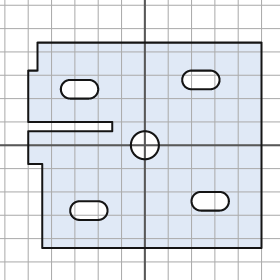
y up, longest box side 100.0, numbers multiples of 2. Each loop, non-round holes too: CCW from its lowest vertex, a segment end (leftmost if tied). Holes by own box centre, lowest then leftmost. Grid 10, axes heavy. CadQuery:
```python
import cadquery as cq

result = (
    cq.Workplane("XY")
    .moveTo(-44.0, -44.0)
    .lineTo(50.0, -44.0)
    .lineTo(50.0, 44.0)
    .lineTo(-46.0, 44.0)
    .lineTo(-46.0, 32.0)
    .lineTo(-50.0, 32.0)
    .lineTo(-50.0, 10.0)
    .lineTo(-14.0, 10.0)
    .lineTo(-14.0, 6.0)
    .lineTo(-50.0, 6.0)
    .lineTo(-50.0, -8.0)
    .lineTo(-44.0, -8.0)
    .close()
    .moveTo(-28.0, -32.0)
    .lineTo(-20.0, -32.0)
    .threePointArc((-16.0, -28.0), (-20.0, -24.0))
    .lineTo(-28.0, -24.0)
    .threePointArc((-32.0, -28.0), (-28.0, -32.0))
    .close()
    .moveTo(24.0, -28.0)
    .lineTo(32.0, -28.0)
    .threePointArc((36.0, -24.0), (32.0, -20.0))
    .lineTo(24.0, -20.0)
    .threePointArc((20.0, -24.0), (24.0, -28.0))
    .close()
    .moveTo(0.0, 0.0)
    .circle(6.0)
    .moveTo(-32.0, 20.0)
    .lineTo(-24.0, 20.0)
    .threePointArc((-20.0, 24.0), (-24.0, 28.0))
    .lineTo(-32.0, 28.0)
    .threePointArc((-36.0, 24.0), (-32.0, 20.0))
    .close()
    .moveTo(20.0, 24.0)
    .lineTo(28.0, 24.0)
    .threePointArc((32.0, 28.0), (28.0, 32.0))
    .lineTo(20.0, 32.0)
    .threePointArc((16.0, 28.0), (20.0, 24.0))
    .close()
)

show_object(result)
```